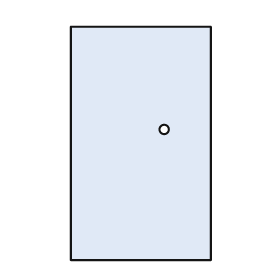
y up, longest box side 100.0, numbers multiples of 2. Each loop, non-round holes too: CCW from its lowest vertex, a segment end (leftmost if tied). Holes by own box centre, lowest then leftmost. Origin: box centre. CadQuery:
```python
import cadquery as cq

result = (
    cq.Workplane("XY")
    .moveTo(-30.0, -50.0)
    .lineTo(30.0, -50.0)
    .lineTo(30.0, 50.0)
    .lineTo(-30.0, 50.0)
    .close()
    .moveTo(10.0, 6.0)
    .circle(2.0)
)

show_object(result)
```